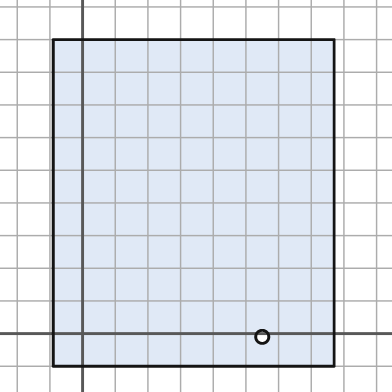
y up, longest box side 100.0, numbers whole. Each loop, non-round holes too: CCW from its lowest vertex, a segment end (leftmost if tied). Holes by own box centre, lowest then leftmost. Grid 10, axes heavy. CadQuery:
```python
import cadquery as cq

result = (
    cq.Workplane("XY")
    .moveTo(-9.0, -10.0)
    .lineTo(77.0, -10.0)
    .lineTo(77.0, 90.0)
    .lineTo(-9.0, 90.0)
    .close()
    .moveTo(55.0, -1.0)
    .circle(2.0)
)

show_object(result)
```